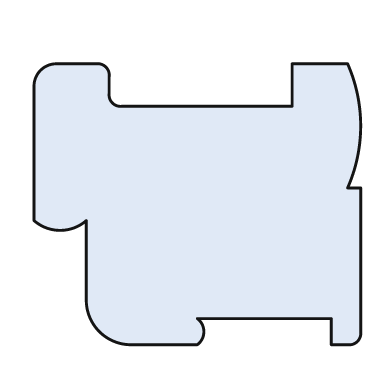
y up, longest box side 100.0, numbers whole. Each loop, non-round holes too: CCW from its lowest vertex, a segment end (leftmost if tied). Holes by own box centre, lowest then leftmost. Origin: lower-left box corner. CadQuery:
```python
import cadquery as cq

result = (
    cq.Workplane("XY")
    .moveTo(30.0, 0.0)
    .lineTo(50.0, 0.0)
    .threePointArc((52.0, 4.0), (50.0, 8.0))
    .lineTo(91.0, 8.0)
    .lineTo(91.0, 0.0)
    .lineTo(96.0, 0.0)
    .threePointArc((99.0, 1.0), (100.0, 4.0))
    .lineTo(100.0, 48.0)
    .lineTo(96.0, 48.0)
    .threePointArc((100.0, 67.0), (96.0, 86.0))
    .lineTo(79.0, 86.0)
    .lineTo(79.0, 73.0)
    .lineTo(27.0, 73.0)
    .threePointArc((24.0, 74.0), (23.0, 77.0))
    .lineTo(23.0, 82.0)
    .threePointArc((22.0, 85.0), (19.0, 86.0))
    .lineTo(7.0, 86.0)
    .threePointArc((2.0, 84.0), (0.0, 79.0))
    .lineTo(0.0, 38.0)
    .threePointArc((8.0, 35.0), (16.0, 38.0))
    .lineTo(16.0, 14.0)
    .threePointArc((20.0, 4.0), (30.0, 0.0))
    .close()
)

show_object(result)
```